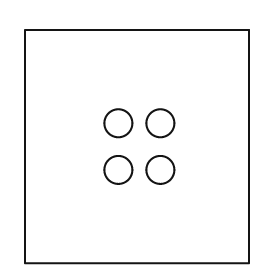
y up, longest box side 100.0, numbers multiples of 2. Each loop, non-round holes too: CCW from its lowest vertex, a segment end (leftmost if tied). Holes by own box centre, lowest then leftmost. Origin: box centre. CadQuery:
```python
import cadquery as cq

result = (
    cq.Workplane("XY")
    .moveTo(-48.0, -50.0)
    .lineTo(48.0, -50.0)
    .lineTo(48.0, 50.0)
    .lineTo(-48.0, 50.0)
    .close()
    .moveTo(-8.0, -10.0)
    .circle(6.0)
    .moveTo(10.0, -10.0)
    .circle(6.0)
    .moveTo(-8.0, 10.0)
    .circle(6.0)
    .moveTo(10.0, 10.0)
    .circle(6.0)
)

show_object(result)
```